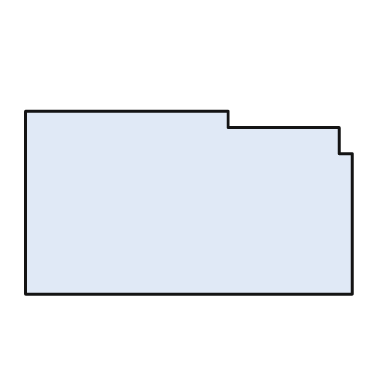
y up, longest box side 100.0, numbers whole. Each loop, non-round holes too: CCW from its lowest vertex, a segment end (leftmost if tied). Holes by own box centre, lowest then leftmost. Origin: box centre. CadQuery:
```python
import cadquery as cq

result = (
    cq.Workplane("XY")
    .moveTo(-50.0, -28.0)
    .lineTo(50.0, -28.0)
    .lineTo(50.0, 15.0)
    .lineTo(46.0, 15.0)
    .lineTo(46.0, 23.0)
    .lineTo(12.0, 23.0)
    .lineTo(12.0, 28.0)
    .lineTo(-50.0, 28.0)
    .close()
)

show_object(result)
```